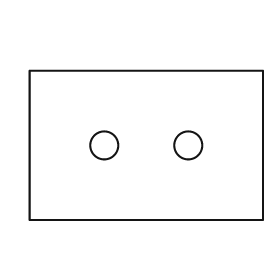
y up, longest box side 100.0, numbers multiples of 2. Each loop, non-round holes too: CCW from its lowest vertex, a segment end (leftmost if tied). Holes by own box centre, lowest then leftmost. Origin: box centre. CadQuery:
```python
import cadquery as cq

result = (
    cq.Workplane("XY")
    .moveTo(-50.0, -32.0)
    .lineTo(50.0, -32.0)
    .lineTo(50.0, 32.0)
    .lineTo(-50.0, 32.0)
    .close()
    .moveTo(-18.0, 0.0)
    .circle(6.0)
    .moveTo(18.0, 0.0)
    .circle(6.0)
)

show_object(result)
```